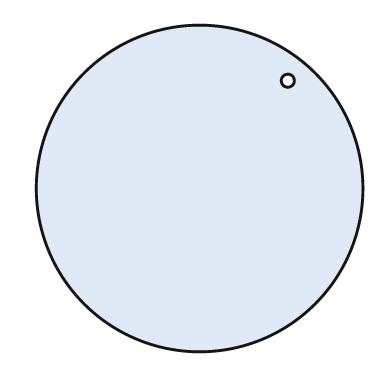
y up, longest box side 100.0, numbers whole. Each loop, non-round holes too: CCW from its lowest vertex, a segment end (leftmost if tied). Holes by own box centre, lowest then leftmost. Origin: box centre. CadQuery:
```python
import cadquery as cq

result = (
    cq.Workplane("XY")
    .moveTo(0.0, 0.0)
    .circle(50.0)
    .moveTo(27.0, 33.0)
    .circle(2.0)
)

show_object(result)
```